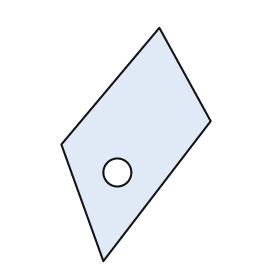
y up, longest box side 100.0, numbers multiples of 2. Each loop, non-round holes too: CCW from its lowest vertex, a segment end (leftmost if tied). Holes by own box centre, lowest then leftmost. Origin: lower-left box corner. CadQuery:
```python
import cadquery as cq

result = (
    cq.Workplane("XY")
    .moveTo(18.0, 0.0)
    .lineTo(64.0, 60.0)
    .lineTo(42.0, 100.0)
    .lineTo(0.0, 50.0)
    .close()
    .moveTo(24.0, 38.0)
    .circle(6.0)
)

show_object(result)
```